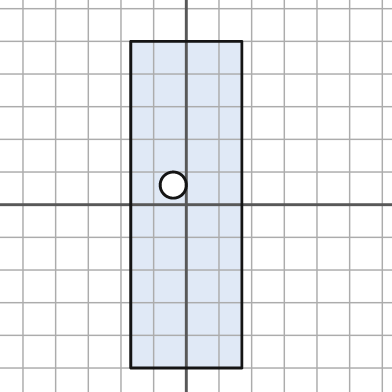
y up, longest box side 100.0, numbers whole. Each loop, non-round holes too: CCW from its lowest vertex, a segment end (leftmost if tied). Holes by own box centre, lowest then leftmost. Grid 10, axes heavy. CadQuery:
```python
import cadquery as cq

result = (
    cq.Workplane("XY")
    .moveTo(-17.0, -50.0)
    .lineTo(17.0, -50.0)
    .lineTo(17.0, 50.0)
    .lineTo(-17.0, 50.0)
    .close()
    .moveTo(-4.0, 6.0)
    .circle(4.0)
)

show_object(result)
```